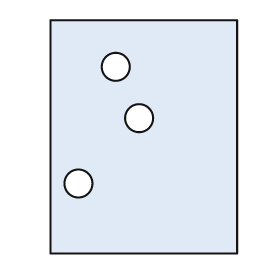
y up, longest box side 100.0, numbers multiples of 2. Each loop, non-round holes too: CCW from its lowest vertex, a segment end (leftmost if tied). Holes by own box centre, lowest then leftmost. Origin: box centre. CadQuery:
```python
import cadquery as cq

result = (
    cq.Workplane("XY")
    .moveTo(-40.0, -50.0)
    .lineTo(40.0, -50.0)
    .lineTo(40.0, 50.0)
    .lineTo(-40.0, 50.0)
    .close()
    .moveTo(-28.0, -20.0)
    .circle(6.0)
    .moveTo(-2.0, 8.0)
    .circle(6.0)
    .moveTo(-12.0, 30.0)
    .circle(6.0)
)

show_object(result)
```